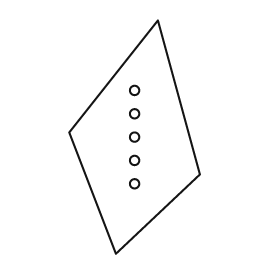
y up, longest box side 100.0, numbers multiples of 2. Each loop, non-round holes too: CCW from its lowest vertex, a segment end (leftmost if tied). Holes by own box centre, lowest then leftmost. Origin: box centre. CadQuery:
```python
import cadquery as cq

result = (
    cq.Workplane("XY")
    .moveTo(-8.0, -50.0)
    .lineTo(28.0, -16.0)
    .lineTo(10.0, 50.0)
    .lineTo(-28.0, 2.0)
    .close()
    .moveTo(0.0, -20.0)
    .circle(2.0)
    .moveTo(0.0, -10.0)
    .circle(2.0)
    .moveTo(0.0, 0.0)
    .circle(2.0)
    .moveTo(0.0, 10.0)
    .circle(2.0)
    .moveTo(0.0, 20.0)
    .circle(2.0)
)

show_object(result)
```